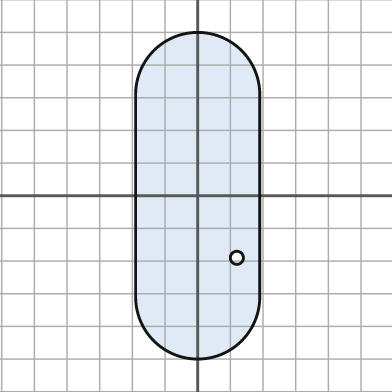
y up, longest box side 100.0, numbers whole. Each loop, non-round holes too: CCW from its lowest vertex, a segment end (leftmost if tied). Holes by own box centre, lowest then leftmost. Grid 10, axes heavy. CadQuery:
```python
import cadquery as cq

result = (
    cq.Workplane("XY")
    .moveTo(-19.0, -31.0)
    .threePointArc((0.0, -50.0), (19.0, -31.0))
    .lineTo(19.0, 31.0)
    .threePointArc((0.0, 50.0), (-19.0, 31.0))
    .close()
    .moveTo(12.0, -19.0)
    .circle(2.0)
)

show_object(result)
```